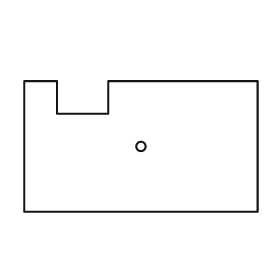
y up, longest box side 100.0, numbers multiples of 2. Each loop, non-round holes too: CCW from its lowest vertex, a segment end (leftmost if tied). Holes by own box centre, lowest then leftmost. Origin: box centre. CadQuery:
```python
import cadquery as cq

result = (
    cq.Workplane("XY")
    .moveTo(-50.0, -28.0)
    .lineTo(50.0, -28.0)
    .lineTo(50.0, 28.0)
    .lineTo(-14.0, 28.0)
    .lineTo(-14.0, 14.0)
    .lineTo(-36.0, 14.0)
    .lineTo(-36.0, 28.0)
    .lineTo(-50.0, 28.0)
    .close()
    .moveTo(0.0, 0.0)
    .circle(2.0)
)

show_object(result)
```